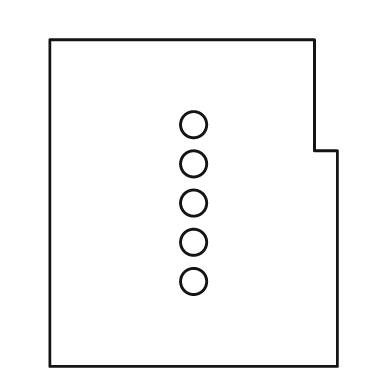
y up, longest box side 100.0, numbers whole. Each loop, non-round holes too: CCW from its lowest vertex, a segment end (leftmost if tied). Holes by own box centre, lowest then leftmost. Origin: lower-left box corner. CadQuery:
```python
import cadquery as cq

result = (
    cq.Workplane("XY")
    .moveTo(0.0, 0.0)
    .lineTo(88.0, 0.0)
    .lineTo(88.0, 66.0)
    .lineTo(81.0, 66.0)
    .lineTo(81.0, 100.0)
    .lineTo(0.0, 100.0)
    .close()
    .moveTo(44.0, 26.0)
    .circle(4.0)
    .moveTo(44.0, 38.0)
    .circle(4.0)
    .moveTo(44.0, 50.0)
    .circle(4.0)
    .moveTo(44.0, 62.0)
    .circle(4.0)
    .moveTo(44.0, 74.0)
    .circle(4.0)
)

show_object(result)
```